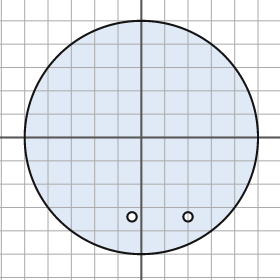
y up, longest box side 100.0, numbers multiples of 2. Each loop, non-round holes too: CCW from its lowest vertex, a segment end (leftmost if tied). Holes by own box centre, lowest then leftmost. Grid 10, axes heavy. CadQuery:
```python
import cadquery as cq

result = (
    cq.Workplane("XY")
    .moveTo(0.0, 0.0)
    .circle(50.0)
    .moveTo(-4.0, -34.0)
    .circle(2.0)
    .moveTo(20.0, -34.0)
    .circle(2.0)
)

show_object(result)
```